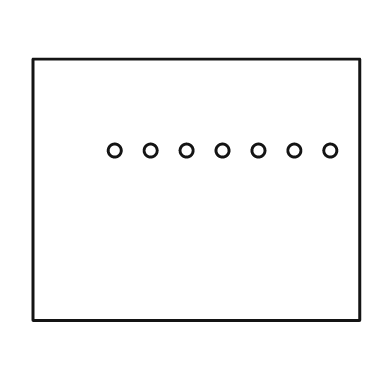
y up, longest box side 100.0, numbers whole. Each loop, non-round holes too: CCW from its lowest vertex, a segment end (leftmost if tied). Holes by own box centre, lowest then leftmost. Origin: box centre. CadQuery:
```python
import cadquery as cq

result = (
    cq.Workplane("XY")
    .moveTo(-50.0, -40.0)
    .lineTo(50.0, -40.0)
    .lineTo(50.0, 40.0)
    .lineTo(-50.0, 40.0)
    .close()
    .moveTo(-25.0, 12.0)
    .circle(2.0)
    .moveTo(-14.0, 12.0)
    .circle(2.0)
    .moveTo(-3.0, 12.0)
    .circle(2.0)
    .moveTo(8.0, 12.0)
    .circle(2.0)
    .moveTo(19.0, 12.0)
    .circle(2.0)
    .moveTo(30.0, 12.0)
    .circle(2.0)
    .moveTo(41.0, 12.0)
    .circle(2.0)
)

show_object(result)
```